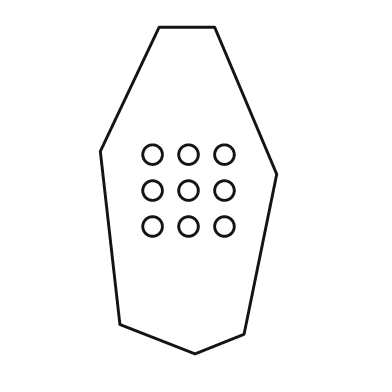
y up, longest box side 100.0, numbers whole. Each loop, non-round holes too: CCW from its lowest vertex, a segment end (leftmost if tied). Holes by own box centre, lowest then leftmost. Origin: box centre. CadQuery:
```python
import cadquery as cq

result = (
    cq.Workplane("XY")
    .moveTo(2.0, -50.0)
    .lineTo(17.0, -44.0)
    .lineTo(27.0, 5.0)
    .lineTo(8.0, 50.0)
    .lineTo(-9.0, 50.0)
    .lineTo(-27.0, 12.0)
    .lineTo(-21.0, -41.0)
    .close()
    .moveTo(-11.0, -11.0)
    .circle(3.0)
    .moveTo(0.0, -11.0)
    .circle(3.0)
    .moveTo(11.0, -11.0)
    .circle(3.0)
    .moveTo(-11.0, 0.0)
    .circle(3.0)
    .moveTo(0.0, 0.0)
    .circle(3.0)
    .moveTo(11.0, 0.0)
    .circle(3.0)
    .moveTo(-11.0, 11.0)
    .circle(3.0)
    .moveTo(0.0, 11.0)
    .circle(3.0)
    .moveTo(11.0, 11.0)
    .circle(3.0)
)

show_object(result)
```